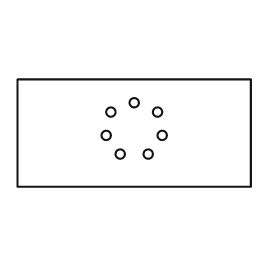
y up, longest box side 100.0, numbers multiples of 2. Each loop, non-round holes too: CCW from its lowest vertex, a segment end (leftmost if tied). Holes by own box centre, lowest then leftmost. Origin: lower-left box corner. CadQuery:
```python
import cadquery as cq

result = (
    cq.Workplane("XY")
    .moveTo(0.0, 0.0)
    .lineTo(100.0, 0.0)
    .lineTo(100.0, 46.0)
    .lineTo(0.0, 46.0)
    .close()
    .moveTo(44.0, 14.0)
    .circle(2.0)
    .moveTo(56.0, 14.0)
    .circle(2.0)
    .moveTo(38.0, 22.0)
    .circle(2.0)
    .moveTo(62.0, 22.0)
    .circle(2.0)
    .moveTo(40.0, 32.0)
    .circle(2.0)
    .moveTo(60.0, 32.0)
    .circle(2.0)
    .moveTo(50.0, 36.0)
    .circle(2.0)
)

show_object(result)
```